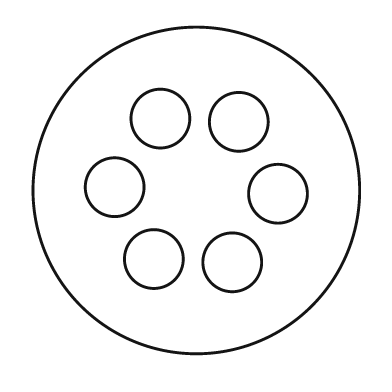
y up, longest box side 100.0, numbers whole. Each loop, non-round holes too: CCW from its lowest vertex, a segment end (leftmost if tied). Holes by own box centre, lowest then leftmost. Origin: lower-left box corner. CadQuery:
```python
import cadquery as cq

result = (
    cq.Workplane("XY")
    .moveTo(50.0, 50.0)
    .circle(50.0)
    .moveTo(61.0, 28.0)
    .circle(9.0)
    .moveTo(37.0, 29.0)
    .circle(9.0)
    .moveTo(75.0, 49.0)
    .circle(9.0)
    .moveTo(25.0, 51.0)
    .circle(9.0)
    .moveTo(63.0, 71.0)
    .circle(9.0)
    .moveTo(39.0, 72.0)
    .circle(9.0)
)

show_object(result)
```